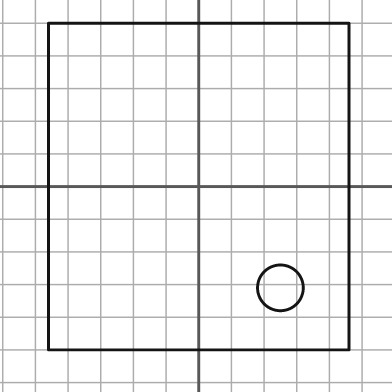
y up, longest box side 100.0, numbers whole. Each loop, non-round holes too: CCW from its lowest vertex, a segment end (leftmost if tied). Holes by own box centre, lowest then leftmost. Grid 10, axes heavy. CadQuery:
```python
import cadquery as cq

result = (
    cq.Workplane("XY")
    .moveTo(-46.0, -50.0)
    .lineTo(46.0, -50.0)
    .lineTo(46.0, 50.0)
    .lineTo(-46.0, 50.0)
    .close()
    .moveTo(25.0, -31.0)
    .circle(7.0)
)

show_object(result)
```